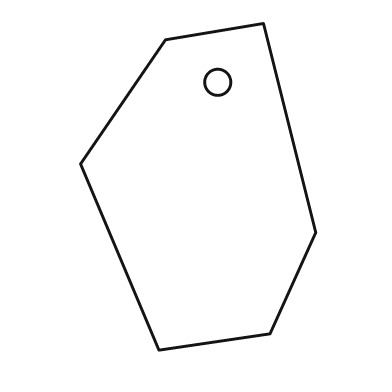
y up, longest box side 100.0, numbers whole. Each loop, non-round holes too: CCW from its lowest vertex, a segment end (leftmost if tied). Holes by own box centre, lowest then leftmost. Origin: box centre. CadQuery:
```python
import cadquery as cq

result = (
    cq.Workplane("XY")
    .moveTo(-12.0, -50.0)
    .lineTo(22.0, -45.0)
    .lineTo(36.0, -14.0)
    .lineTo(20.0, 50.0)
    .lineTo(-10.0, 45.0)
    .lineTo(-36.0, 7.0)
    .close()
    .moveTo(6.0, 32.0)
    .circle(4.0)
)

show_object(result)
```